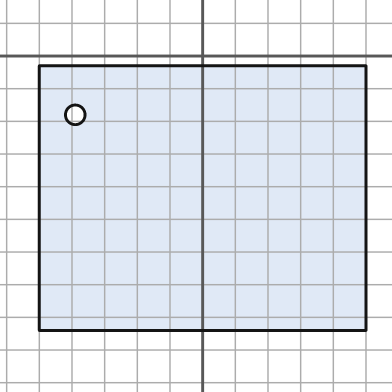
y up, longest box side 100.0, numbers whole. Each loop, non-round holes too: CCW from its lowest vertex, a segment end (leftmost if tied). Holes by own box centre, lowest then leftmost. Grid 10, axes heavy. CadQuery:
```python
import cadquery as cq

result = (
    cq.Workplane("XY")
    .moveTo(-50.0, -84.0)
    .lineTo(50.0, -84.0)
    .lineTo(50.0, -3.0)
    .lineTo(-50.0, -3.0)
    .close()
    .moveTo(-39.0, -18.0)
    .circle(3.0)
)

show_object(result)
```